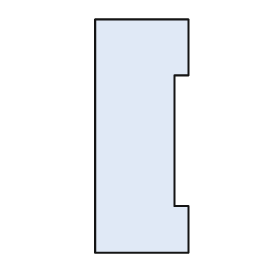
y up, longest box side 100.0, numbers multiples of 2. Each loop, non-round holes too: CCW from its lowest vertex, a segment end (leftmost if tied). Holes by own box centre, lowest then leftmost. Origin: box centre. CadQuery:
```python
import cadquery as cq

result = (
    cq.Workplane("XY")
    .moveTo(-20.0, -50.0)
    .lineTo(20.0, -50.0)
    .lineTo(20.0, -30.0)
    .lineTo(14.0, -30.0)
    .lineTo(14.0, 26.0)
    .lineTo(20.0, 26.0)
    .lineTo(20.0, 50.0)
    .lineTo(-20.0, 50.0)
    .close()
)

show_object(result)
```